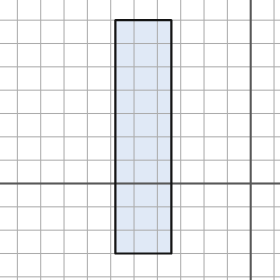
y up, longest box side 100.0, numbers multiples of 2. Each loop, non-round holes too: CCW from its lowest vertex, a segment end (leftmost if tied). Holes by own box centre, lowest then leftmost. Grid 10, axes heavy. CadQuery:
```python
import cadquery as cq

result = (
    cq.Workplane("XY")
    .moveTo(-58.0, -30.0)
    .lineTo(-34.0, -30.0)
    .lineTo(-34.0, 70.0)
    .lineTo(-58.0, 70.0)
    .close()
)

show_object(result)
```